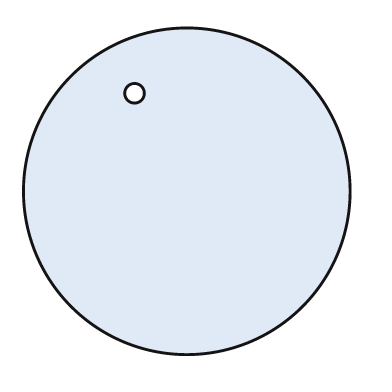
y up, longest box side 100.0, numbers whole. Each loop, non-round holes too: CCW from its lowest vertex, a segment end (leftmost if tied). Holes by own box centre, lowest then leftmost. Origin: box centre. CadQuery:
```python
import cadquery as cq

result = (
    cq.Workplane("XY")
    .moveTo(0.0, 0.0)
    .circle(50.0)
    .moveTo(-16.0, 30.0)
    .circle(3.0)
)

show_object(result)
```